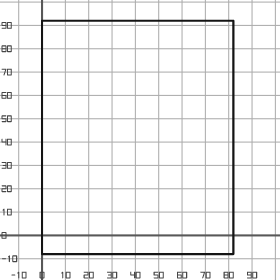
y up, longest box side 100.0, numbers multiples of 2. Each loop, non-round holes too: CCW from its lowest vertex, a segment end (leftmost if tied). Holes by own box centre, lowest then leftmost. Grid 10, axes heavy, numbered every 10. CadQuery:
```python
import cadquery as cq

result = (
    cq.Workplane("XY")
    .moveTo(0.0, -8.0)
    .lineTo(82.0, -8.0)
    .lineTo(82.0, 92.0)
    .lineTo(0.0, 92.0)
    .close()
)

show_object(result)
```